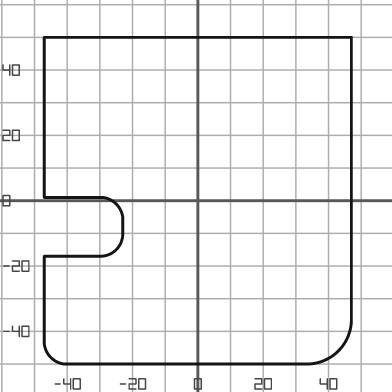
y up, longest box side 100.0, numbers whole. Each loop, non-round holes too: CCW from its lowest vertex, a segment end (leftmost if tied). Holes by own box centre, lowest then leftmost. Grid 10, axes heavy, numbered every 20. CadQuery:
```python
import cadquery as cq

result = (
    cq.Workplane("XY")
    .moveTo(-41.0, -50.0)
    .lineTo(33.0, -50.0)
    .threePointArc((43.0, -46.0), (47.0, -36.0))
    .lineTo(47.0, 50.0)
    .lineTo(-47.0, 50.0)
    .lineTo(-47.0, 1.0)
    .lineTo(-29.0, 1.0)
    .threePointArc((-25.0, -1.0), (-23.0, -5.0))
    .lineTo(-23.0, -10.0)
    .threePointArc((-25.0, -15.0), (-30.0, -17.0))
    .lineTo(-47.0, -17.0)
    .lineTo(-47.0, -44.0)
    .threePointArc((-45.0, -48.0), (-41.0, -50.0))
    .close()
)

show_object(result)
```